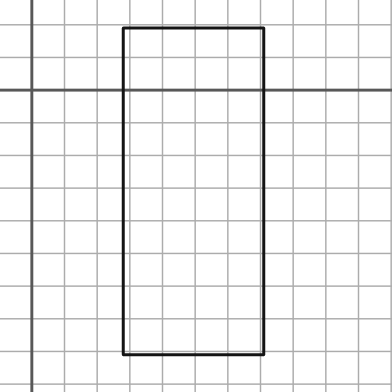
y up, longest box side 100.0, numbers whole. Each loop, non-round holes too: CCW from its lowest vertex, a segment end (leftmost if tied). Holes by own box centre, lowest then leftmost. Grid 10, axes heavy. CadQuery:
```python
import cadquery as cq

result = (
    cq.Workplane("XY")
    .moveTo(28.0, -81.0)
    .lineTo(71.0, -81.0)
    .lineTo(71.0, 19.0)
    .lineTo(28.0, 19.0)
    .close()
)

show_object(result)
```